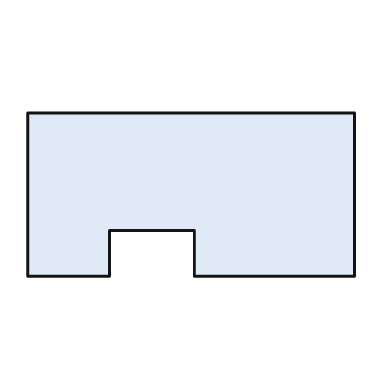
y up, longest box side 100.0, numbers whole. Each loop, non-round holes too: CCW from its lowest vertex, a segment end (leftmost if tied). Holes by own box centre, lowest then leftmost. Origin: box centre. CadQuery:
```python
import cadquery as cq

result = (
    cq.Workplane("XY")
    .moveTo(-50.0, -25.0)
    .lineTo(-25.0, -25.0)
    .lineTo(-25.0, -11.0)
    .lineTo(1.0, -11.0)
    .lineTo(1.0, -25.0)
    .lineTo(50.0, -25.0)
    .lineTo(50.0, 25.0)
    .lineTo(-50.0, 25.0)
    .close()
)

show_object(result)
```